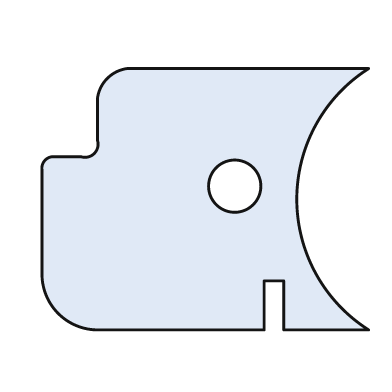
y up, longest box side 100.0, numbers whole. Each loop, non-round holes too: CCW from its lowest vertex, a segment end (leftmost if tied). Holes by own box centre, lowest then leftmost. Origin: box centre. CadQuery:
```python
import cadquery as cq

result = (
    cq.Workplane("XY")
    .moveTo(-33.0, -40.0)
    .lineTo(18.0, -40.0)
    .lineTo(18.0, -25.0)
    .lineTo(24.0, -25.0)
    .lineTo(24.0, -40.0)
    .lineTo(50.0, -40.0)
    .threePointArc((28.0, 0.0), (50.0, 40.0))
    .lineTo(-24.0, 40.0)
    .threePointArc((-30.0, 37.0), (-33.0, 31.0))
    .lineTo(-33.0, 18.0)
    .threePointArc((-34.0, 14.0), (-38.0, 13.0))
    .lineTo(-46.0, 13.0)
    .threePointArc((-49.0, 12.0), (-50.0, 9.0))
    .lineTo(-50.0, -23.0)
    .threePointArc((-45.0, -35.0), (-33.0, -40.0))
    .close()
    .moveTo(9.0, 4.0)
    .circle(8.0)
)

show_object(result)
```